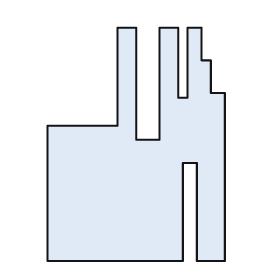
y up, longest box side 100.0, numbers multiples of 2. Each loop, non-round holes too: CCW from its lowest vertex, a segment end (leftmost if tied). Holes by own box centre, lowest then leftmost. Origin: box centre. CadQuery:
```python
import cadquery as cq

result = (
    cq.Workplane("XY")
    .moveTo(-38.0, -50.0)
    .lineTo(20.0, -50.0)
    .lineTo(20.0, -8.0)
    .lineTo(26.0, -8.0)
    .lineTo(26.0, -50.0)
    .lineTo(38.0, -50.0)
    .lineTo(38.0, 22.0)
    .lineTo(32.0, 22.0)
    .lineTo(32.0, 36.0)
    .lineTo(28.0, 36.0)
    .lineTo(28.0, 50.0)
    .lineTo(22.0, 50.0)
    .lineTo(22.0, 20.0)
    .lineTo(18.0, 20.0)
    .lineTo(18.0, 50.0)
    .lineTo(10.0, 50.0)
    .lineTo(10.0, 2.0)
    .lineTo(0.0, 2.0)
    .lineTo(0.0, 50.0)
    .lineTo(-8.0, 50.0)
    .lineTo(-8.0, 8.0)
    .lineTo(-38.0, 8.0)
    .close()
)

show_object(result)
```